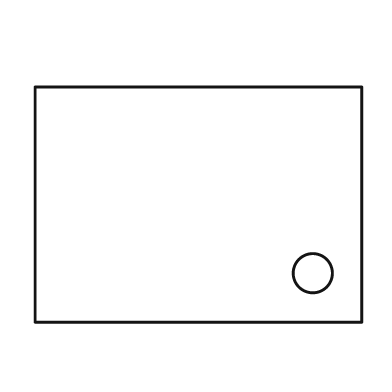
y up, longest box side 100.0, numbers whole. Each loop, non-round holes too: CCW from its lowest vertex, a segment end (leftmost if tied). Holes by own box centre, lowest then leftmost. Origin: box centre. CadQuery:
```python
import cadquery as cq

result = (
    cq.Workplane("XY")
    .moveTo(-50.0, -36.0)
    .lineTo(50.0, -36.0)
    .lineTo(50.0, 36.0)
    .lineTo(-50.0, 36.0)
    .close()
    .moveTo(35.0, -21.0)
    .circle(6.0)
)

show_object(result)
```